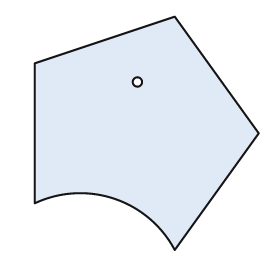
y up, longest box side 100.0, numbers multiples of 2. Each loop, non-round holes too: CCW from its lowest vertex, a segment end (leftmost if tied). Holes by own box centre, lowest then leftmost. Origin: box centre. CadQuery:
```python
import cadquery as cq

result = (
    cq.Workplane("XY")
    .moveTo(12.0, -50.0)
    .lineTo(48.0, 0.0)
    .lineTo(12.0, 50.0)
    .lineTo(-48.0, 30.0)
    .lineTo(-48.0, -30.0)
    .threePointArc((-14.0, -28.0), (12.0, -50.0))
    .close()
    .moveTo(-4.0, 22.0)
    .circle(2.0)
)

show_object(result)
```